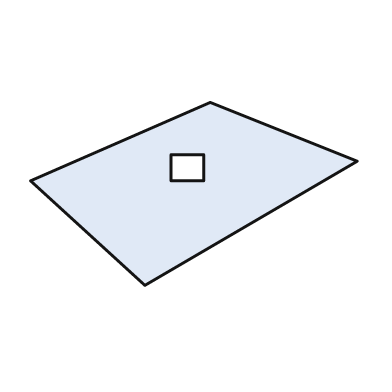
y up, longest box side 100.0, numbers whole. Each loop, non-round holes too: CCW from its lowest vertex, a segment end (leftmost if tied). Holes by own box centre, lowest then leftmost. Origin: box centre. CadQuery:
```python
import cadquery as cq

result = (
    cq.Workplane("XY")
    .moveTo(-15.0, -28.0)
    .lineTo(50.0, 10.0)
    .lineTo(5.0, 28.0)
    .lineTo(-50.0, 4.0)
    .close()
    .moveTo(-7.0, 4.0)
    .lineTo(3.0, 4.0)
    .lineTo(3.0, 12.0)
    .lineTo(-7.0, 12.0)
    .close()
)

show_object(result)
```